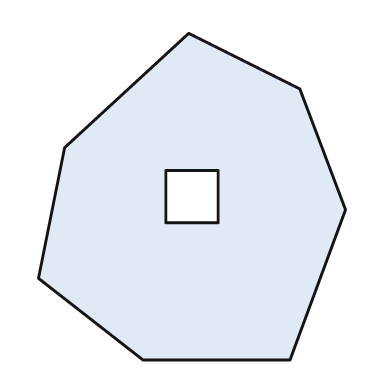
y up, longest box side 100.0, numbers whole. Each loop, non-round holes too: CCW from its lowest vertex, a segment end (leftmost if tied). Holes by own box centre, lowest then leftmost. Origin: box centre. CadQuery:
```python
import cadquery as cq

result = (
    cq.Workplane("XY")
    .moveTo(-15.0, -50.0)
    .lineTo(30.0, -50.0)
    .lineTo(47.0, -4.0)
    .lineTo(33.0, 33.0)
    .lineTo(-1.0, 50.0)
    .lineTo(-39.0, 15.0)
    .lineTo(-47.0, -25.0)
    .close()
    .moveTo(-8.0, -8.0)
    .lineTo(8.0, -8.0)
    .lineTo(8.0, 8.0)
    .lineTo(-8.0, 8.0)
    .close()
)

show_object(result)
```